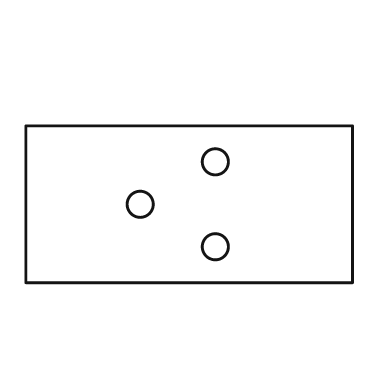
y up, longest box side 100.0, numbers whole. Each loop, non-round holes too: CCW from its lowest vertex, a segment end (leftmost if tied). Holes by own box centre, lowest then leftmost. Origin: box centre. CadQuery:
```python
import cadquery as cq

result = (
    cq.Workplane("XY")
    .moveTo(-50.0, -24.0)
    .lineTo(50.0, -24.0)
    .lineTo(50.0, 24.0)
    .lineTo(-50.0, 24.0)
    .close()
    .moveTo(8.0, -13.0)
    .circle(4.0)
    .moveTo(-15.0, 0.0)
    .circle(4.0)
    .moveTo(8.0, 13.0)
    .circle(4.0)
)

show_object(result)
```